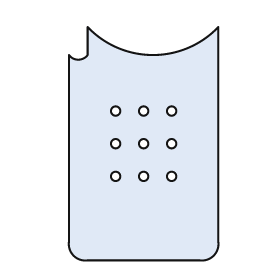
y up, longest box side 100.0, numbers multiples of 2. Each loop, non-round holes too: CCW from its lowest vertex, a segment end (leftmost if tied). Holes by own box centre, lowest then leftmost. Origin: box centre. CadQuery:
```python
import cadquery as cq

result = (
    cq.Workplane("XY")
    .moveTo(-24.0, -50.0)
    .lineTo(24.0, -50.0)
    .threePointArc((30.0, -48.0), (32.0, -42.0))
    .lineTo(32.0, 50.0)
    .threePointArc((4.0, 38.0), (-24.0, 50.0))
    .lineTo(-24.0, 38.0)
    .threePointArc((-28.0, 36.0), (-32.0, 38.0))
    .lineTo(-32.0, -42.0)
    .threePointArc((-30.0, -48.0), (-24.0, -50.0))
    .close()
    .moveTo(-12.0, -14.0)
    .circle(2.0)
    .moveTo(0.0, -14.0)
    .circle(2.0)
    .moveTo(12.0, -14.0)
    .circle(2.0)
    .moveTo(-12.0, 0.0)
    .circle(2.0)
    .moveTo(0.0, 0.0)
    .circle(2.0)
    .moveTo(12.0, 0.0)
    .circle(2.0)
    .moveTo(-12.0, 14.0)
    .circle(2.0)
    .moveTo(0.0, 14.0)
    .circle(2.0)
    .moveTo(12.0, 14.0)
    .circle(2.0)
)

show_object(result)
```